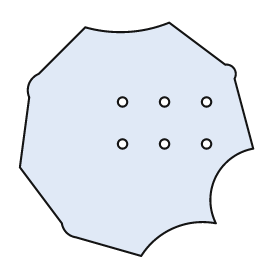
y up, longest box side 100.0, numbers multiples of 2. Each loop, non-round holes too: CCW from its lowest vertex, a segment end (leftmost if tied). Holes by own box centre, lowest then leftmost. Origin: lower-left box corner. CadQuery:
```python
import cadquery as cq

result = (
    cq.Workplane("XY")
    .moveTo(52.0, 0.0)
    .threePointArc((66.0, 12.0), (84.0, 14.0))
    .threePointArc((84.0, 34.0), (100.0, 46.0))
    .lineTo(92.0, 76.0)
    .threePointArc((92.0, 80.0), (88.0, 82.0))
    .lineTo(64.0, 100.0)
    .threePointArc((46.0, 96.0), (28.0, 98.0))
    .lineTo(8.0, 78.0)
    .threePointArc((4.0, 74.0), (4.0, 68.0))
    .lineTo(0.0, 38.0)
    .lineTo(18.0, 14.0)
    .threePointArc((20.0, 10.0), (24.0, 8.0))
    .close()
    .moveTo(44.0, 48.0)
    .circle(2.0)
    .moveTo(62.0, 48.0)
    .circle(2.0)
    .moveTo(80.0, 48.0)
    .circle(2.0)
    .moveTo(44.0, 66.0)
    .circle(2.0)
    .moveTo(62.0, 66.0)
    .circle(2.0)
    .moveTo(80.0, 66.0)
    .circle(2.0)
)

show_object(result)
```